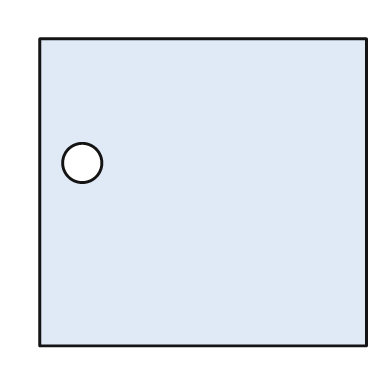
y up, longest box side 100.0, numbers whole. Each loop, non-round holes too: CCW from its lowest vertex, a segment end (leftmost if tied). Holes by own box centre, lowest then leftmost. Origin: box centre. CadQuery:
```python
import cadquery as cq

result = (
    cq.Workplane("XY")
    .moveTo(-50.0, -47.0)
    .lineTo(50.0, -47.0)
    .lineTo(50.0, 47.0)
    .lineTo(-50.0, 47.0)
    .close()
    .moveTo(-37.0, 9.0)
    .circle(6.0)
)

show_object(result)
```